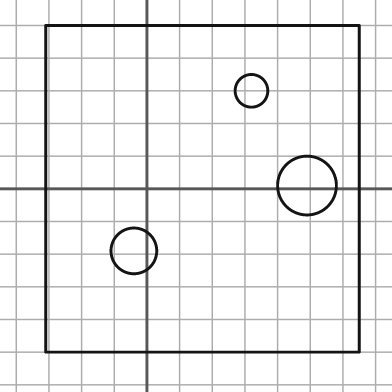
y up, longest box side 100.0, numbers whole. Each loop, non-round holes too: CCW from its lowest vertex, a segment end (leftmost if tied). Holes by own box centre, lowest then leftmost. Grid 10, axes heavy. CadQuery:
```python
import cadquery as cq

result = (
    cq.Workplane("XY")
    .moveTo(-31.0, -50.0)
    .lineTo(65.0, -50.0)
    .lineTo(65.0, 50.0)
    .lineTo(-31.0, 50.0)
    .close()
    .moveTo(-4.0, -19.0)
    .circle(7.0)
    .moveTo(49.0, 1.0)
    .circle(9.0)
    .moveTo(32.0, 30.0)
    .circle(5.0)
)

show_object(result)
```